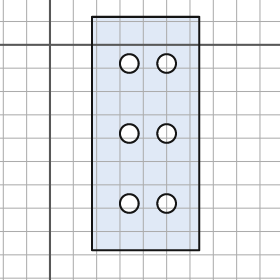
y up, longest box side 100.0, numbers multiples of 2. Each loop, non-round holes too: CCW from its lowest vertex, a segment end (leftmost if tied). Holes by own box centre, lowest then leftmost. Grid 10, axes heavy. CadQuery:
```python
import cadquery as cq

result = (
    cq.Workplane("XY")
    .moveTo(18.0, -88.0)
    .lineTo(64.0, -88.0)
    .lineTo(64.0, 12.0)
    .lineTo(18.0, 12.0)
    .close()
    .moveTo(34.0, -68.0)
    .circle(4.0)
    .moveTo(50.0, -68.0)
    .circle(4.0)
    .moveTo(34.0, -38.0)
    .circle(4.0)
    .moveTo(50.0, -38.0)
    .circle(4.0)
    .moveTo(34.0, -8.0)
    .circle(4.0)
    .moveTo(50.0, -8.0)
    .circle(4.0)
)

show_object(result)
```